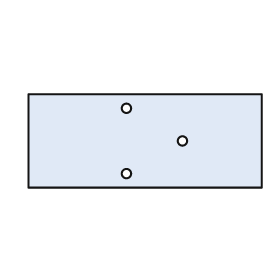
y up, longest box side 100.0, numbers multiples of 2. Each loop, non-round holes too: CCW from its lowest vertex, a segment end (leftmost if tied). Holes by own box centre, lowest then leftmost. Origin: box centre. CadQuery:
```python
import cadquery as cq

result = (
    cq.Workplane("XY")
    .moveTo(-50.0, -20.0)
    .lineTo(50.0, -20.0)
    .lineTo(50.0, 20.0)
    .lineTo(-50.0, 20.0)
    .close()
    .moveTo(-8.0, -14.0)
    .circle(2.0)
    .moveTo(16.0, 0.0)
    .circle(2.0)
    .moveTo(-8.0, 14.0)
    .circle(2.0)
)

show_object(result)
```